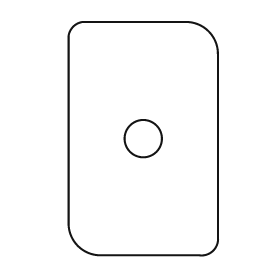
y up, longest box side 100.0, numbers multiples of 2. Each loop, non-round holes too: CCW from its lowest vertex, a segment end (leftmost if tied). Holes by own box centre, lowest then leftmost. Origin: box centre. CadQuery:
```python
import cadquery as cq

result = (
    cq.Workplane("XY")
    .moveTo(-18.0, -50.0)
    .lineTo(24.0, -50.0)
    .threePointArc((30.0, -48.0), (32.0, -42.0))
    .lineTo(32.0, 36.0)
    .threePointArc((28.0, 46.0), (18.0, 50.0))
    .lineTo(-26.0, 50.0)
    .threePointArc((-30.0, 48.0), (-32.0, 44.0))
    .lineTo(-32.0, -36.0)
    .threePointArc((-28.0, -46.0), (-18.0, -50.0))
    .close()
    .moveTo(0.0, 0.0)
    .circle(8.0)
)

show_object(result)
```